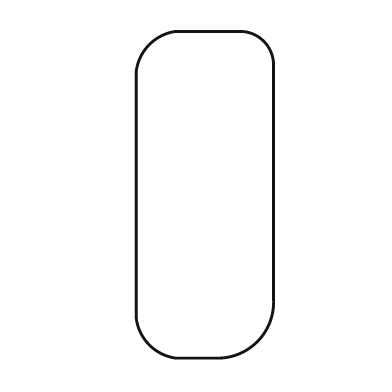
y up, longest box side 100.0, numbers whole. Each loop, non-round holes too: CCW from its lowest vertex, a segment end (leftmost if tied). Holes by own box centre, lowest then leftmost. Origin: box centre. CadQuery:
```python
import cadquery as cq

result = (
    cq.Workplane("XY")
    .moveTo(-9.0, -50.0)
    .lineTo(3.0, -50.0)
    .threePointArc((16.0, -45.0), (21.0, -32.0))
    .lineTo(21.0, 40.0)
    .threePointArc((18.0, 47.0), (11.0, 50.0))
    .lineTo(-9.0, 50.0)
    .threePointArc((-17.0, 46.0), (-21.0, 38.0))
    .lineTo(-21.0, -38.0)
    .threePointArc((-17.0, -46.0), (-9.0, -50.0))
    .close()
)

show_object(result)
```